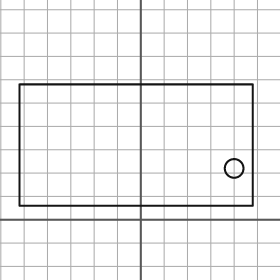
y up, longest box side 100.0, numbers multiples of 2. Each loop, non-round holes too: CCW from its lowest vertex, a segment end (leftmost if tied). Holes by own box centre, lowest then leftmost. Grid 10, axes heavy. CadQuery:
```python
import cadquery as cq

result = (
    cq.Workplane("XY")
    .moveTo(-52.0, 6.0)
    .lineTo(48.0, 6.0)
    .lineTo(48.0, 58.0)
    .lineTo(-52.0, 58.0)
    .close()
    .moveTo(40.0, 22.0)
    .circle(4.0)
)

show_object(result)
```